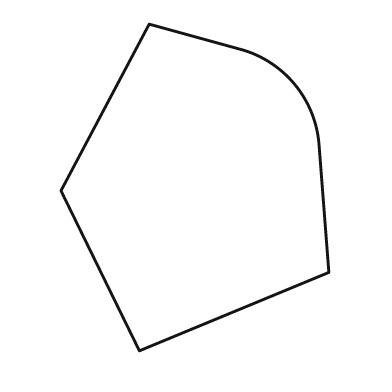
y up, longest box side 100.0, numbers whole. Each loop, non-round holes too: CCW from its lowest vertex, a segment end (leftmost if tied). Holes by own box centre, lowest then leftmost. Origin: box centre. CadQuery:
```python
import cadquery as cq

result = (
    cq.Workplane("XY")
    .moveTo(-17.0, -50.0)
    .lineTo(41.0, -26.0)
    .lineTo(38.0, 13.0)
    .threePointArc((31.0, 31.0), (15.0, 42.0))
    .lineTo(-14.0, 50.0)
    .lineTo(-41.0, -1.0)
    .close()
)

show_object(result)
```